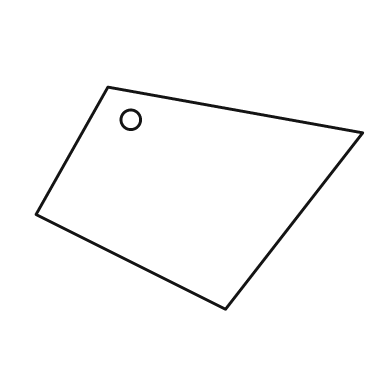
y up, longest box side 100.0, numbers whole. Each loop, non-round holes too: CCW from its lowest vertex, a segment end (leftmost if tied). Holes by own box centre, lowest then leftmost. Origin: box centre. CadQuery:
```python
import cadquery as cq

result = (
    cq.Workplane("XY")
    .moveTo(8.0, -34.0)
    .lineTo(50.0, 20.0)
    .lineTo(-28.0, 34.0)
    .lineTo(-50.0, -5.0)
    .close()
    .moveTo(-21.0, 24.0)
    .circle(3.0)
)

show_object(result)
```